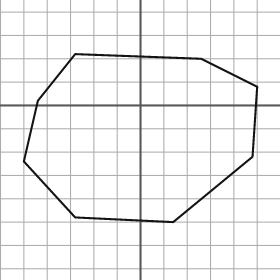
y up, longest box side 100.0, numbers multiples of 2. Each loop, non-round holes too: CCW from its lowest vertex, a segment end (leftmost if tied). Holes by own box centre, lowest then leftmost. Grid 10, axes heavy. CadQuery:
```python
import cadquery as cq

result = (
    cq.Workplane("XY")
    .moveTo(14.0, -50.0)
    .lineTo(48.0, -22.0)
    .lineTo(50.0, 8.0)
    .lineTo(26.0, 20.0)
    .lineTo(-28.0, 22.0)
    .lineTo(-44.0, 2.0)
    .lineTo(-50.0, -24.0)
    .lineTo(-28.0, -48.0)
    .close()
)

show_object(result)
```